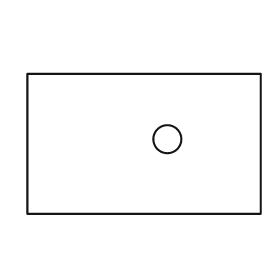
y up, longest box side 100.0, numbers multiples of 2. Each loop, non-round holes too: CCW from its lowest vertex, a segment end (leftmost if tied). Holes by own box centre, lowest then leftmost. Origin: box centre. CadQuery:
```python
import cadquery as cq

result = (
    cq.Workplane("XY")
    .moveTo(-50.0, -30.0)
    .lineTo(50.0, -30.0)
    .lineTo(50.0, 30.0)
    .lineTo(-50.0, 30.0)
    .close()
    .moveTo(10.0, 2.0)
    .circle(6.0)
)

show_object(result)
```